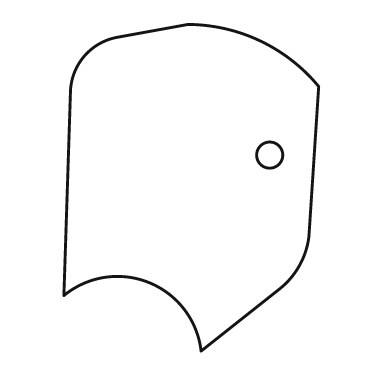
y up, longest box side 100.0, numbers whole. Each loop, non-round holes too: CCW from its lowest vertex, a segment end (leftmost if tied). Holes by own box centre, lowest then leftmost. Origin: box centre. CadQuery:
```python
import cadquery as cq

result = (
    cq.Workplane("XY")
    .moveTo(3.0, -50.0)
    .lineTo(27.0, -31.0)
    .threePointArc((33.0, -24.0), (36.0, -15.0))
    .lineTo(39.0, 31.0)
    .threePointArc((21.0, 45.0), (-1.0, 50.0))
    .lineTo(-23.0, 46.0)
    .threePointArc((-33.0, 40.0), (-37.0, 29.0))
    .lineTo(-39.0, -33.0)
    .threePointArc((-13.0, -29.0), (3.0, -50.0))
    .close()
    .moveTo(24.0, 10.0)
    .circle(4.0)
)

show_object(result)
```